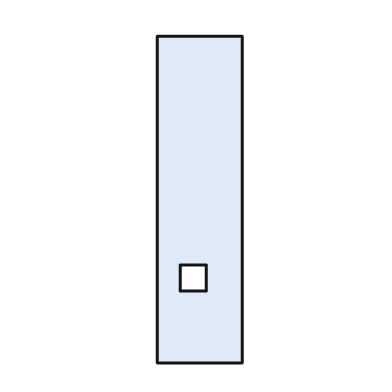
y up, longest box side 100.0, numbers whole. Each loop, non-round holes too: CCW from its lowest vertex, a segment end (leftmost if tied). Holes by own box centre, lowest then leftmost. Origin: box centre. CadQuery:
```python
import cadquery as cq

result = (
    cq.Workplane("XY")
    .moveTo(-13.0, -50.0)
    .lineTo(13.0, -50.0)
    .lineTo(13.0, 50.0)
    .lineTo(-13.0, 50.0)
    .close()
    .moveTo(-6.0, -28.0)
    .lineTo(2.0, -28.0)
    .lineTo(2.0, -20.0)
    .lineTo(-6.0, -20.0)
    .close()
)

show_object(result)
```